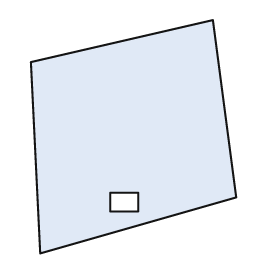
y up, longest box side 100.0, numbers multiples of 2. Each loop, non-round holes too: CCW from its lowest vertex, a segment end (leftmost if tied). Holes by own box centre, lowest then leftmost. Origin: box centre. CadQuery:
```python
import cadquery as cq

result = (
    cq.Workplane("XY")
    .moveTo(-40.0, -50.0)
    .lineTo(44.0, -26.0)
    .lineTo(34.0, 50.0)
    .lineTo(-44.0, 32.0)
    .close()
    .moveTo(-10.0, -32.0)
    .lineTo(2.0, -32.0)
    .lineTo(2.0, -24.0)
    .lineTo(-10.0, -24.0)
    .close()
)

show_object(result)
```